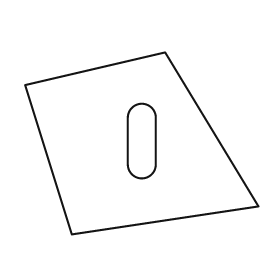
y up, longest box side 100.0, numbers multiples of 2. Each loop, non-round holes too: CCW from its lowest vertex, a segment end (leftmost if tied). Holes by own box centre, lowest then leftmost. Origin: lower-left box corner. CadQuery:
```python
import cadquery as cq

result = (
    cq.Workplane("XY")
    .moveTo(20.0, 0.0)
    .lineTo(100.0, 12.0)
    .lineTo(60.0, 78.0)
    .lineTo(0.0, 64.0)
    .close()
    .moveTo(44.0, 30.0)
    .threePointArc((50.0, 24.0), (56.0, 30.0))
    .lineTo(56.0, 50.0)
    .threePointArc((50.0, 56.0), (44.0, 50.0))
    .close()
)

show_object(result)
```